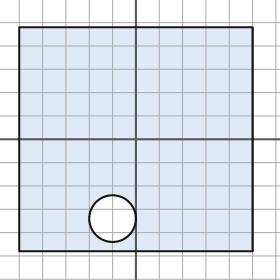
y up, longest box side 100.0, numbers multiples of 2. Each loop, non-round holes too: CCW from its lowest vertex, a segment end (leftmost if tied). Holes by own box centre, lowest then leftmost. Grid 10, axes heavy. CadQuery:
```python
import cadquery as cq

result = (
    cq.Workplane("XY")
    .moveTo(-50.0, -48.0)
    .lineTo(50.0, -48.0)
    .lineTo(50.0, 48.0)
    .lineTo(-50.0, 48.0)
    .close()
    .moveTo(-10.0, -34.0)
    .circle(10.0)
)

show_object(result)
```